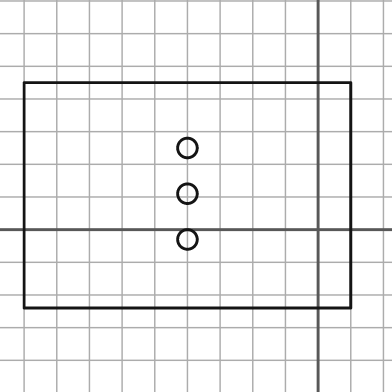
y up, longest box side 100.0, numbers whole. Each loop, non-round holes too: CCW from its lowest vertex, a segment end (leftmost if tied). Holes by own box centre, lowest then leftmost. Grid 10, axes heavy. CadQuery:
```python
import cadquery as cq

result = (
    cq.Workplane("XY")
    .moveTo(-90.0, -24.0)
    .lineTo(10.0, -24.0)
    .lineTo(10.0, 45.0)
    .lineTo(-90.0, 45.0)
    .close()
    .moveTo(-40.0, -3.0)
    .circle(3.0)
    .moveTo(-40.0, 11.0)
    .circle(3.0)
    .moveTo(-40.0, 25.0)
    .circle(3.0)
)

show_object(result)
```